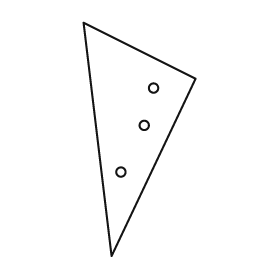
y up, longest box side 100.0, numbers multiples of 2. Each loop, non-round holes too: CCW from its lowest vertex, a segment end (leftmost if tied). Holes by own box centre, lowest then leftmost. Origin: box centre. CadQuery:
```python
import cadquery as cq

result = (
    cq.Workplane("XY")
    .moveTo(-12.0, -50.0)
    .lineTo(24.0, 26.0)
    .lineTo(-24.0, 50.0)
    .close()
    .moveTo(-8.0, -14.0)
    .circle(2.0)
    .moveTo(2.0, 6.0)
    .circle(2.0)
    .moveTo(6.0, 22.0)
    .circle(2.0)
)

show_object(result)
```